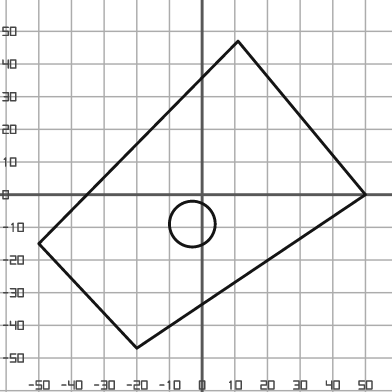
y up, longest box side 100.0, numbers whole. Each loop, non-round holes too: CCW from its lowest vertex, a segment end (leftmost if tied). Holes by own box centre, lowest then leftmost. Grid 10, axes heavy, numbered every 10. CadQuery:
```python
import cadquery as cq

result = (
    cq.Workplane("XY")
    .moveTo(-20.0, -47.0)
    .lineTo(50.0, 0.0)
    .lineTo(11.0, 47.0)
    .lineTo(-50.0, -15.0)
    .close()
    .moveTo(-3.0, -9.0)
    .circle(7.0)
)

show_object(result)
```